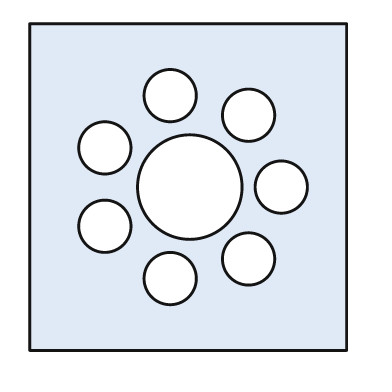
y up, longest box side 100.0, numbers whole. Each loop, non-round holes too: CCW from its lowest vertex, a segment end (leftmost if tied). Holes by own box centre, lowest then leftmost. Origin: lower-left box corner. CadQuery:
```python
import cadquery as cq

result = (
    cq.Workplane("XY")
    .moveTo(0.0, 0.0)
    .lineTo(97.0, 0.0)
    .lineTo(97.0, 100.0)
    .lineTo(0.0, 100.0)
    .close()
    .moveTo(43.0, 22.0)
    .circle(8.0)
    .moveTo(67.0, 28.0)
    .circle(8.0)
    .moveTo(23.0, 38.0)
    .circle(8.0)
    .moveTo(49.0, 50.0)
    .circle(16.0)
    .moveTo(77.0, 50.0)
    .circle(8.0)
    .moveTo(23.0, 62.0)
    .circle(8.0)
    .moveTo(67.0, 72.0)
    .circle(8.0)
    .moveTo(43.0, 78.0)
    .circle(8.0)
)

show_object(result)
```